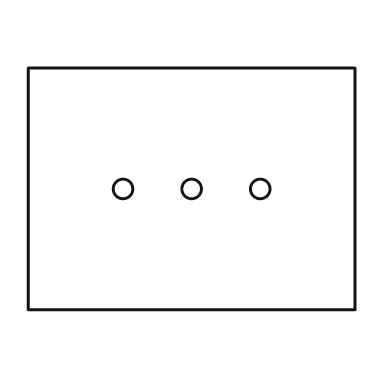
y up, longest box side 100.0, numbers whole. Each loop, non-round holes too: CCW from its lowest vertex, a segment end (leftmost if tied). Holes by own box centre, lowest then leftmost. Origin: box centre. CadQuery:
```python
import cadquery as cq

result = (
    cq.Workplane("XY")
    .moveTo(-50.0, -37.0)
    .lineTo(50.0, -37.0)
    .lineTo(50.0, 37.0)
    .lineTo(-50.0, 37.0)
    .close()
    .moveTo(-21.0, 0.0)
    .circle(3.0)
    .moveTo(0.0, 0.0)
    .circle(3.0)
    .moveTo(21.0, 0.0)
    .circle(3.0)
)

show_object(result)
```